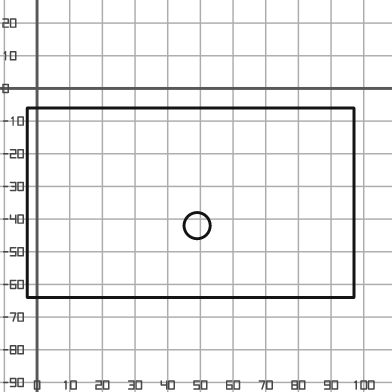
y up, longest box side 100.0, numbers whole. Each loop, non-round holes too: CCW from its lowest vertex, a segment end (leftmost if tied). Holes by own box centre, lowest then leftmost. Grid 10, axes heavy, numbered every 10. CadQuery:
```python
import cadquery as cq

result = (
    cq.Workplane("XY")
    .moveTo(-3.0, -64.0)
    .lineTo(97.0, -64.0)
    .lineTo(97.0, -6.0)
    .lineTo(-3.0, -6.0)
    .close()
    .moveTo(49.0, -42.0)
    .circle(4.0)
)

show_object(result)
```